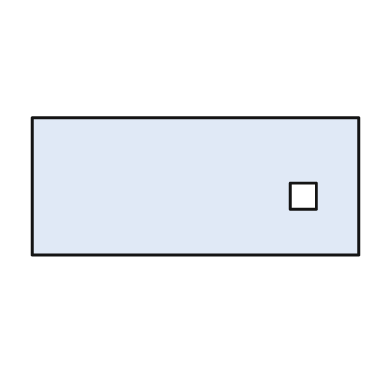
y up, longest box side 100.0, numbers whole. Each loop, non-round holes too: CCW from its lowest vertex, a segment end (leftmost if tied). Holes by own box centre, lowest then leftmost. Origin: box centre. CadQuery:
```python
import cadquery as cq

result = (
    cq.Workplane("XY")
    .moveTo(-50.0, -21.0)
    .lineTo(50.0, -21.0)
    .lineTo(50.0, 21.0)
    .lineTo(-50.0, 21.0)
    .close()
    .moveTo(29.0, -7.0)
    .lineTo(37.0, -7.0)
    .lineTo(37.0, 1.0)
    .lineTo(29.0, 1.0)
    .close()
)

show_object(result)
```